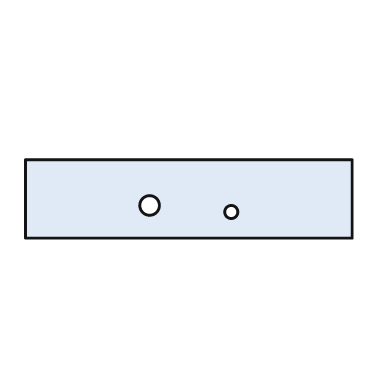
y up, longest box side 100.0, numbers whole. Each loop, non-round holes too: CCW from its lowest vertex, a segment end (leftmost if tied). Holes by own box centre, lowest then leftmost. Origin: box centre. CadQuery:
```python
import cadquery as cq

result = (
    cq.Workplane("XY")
    .moveTo(-50.0, -12.0)
    .lineTo(50.0, -12.0)
    .lineTo(50.0, 12.0)
    .lineTo(-50.0, 12.0)
    .close()
    .moveTo(13.0, -4.0)
    .circle(2.0)
    .moveTo(-12.0, -2.0)
    .circle(3.0)
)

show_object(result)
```